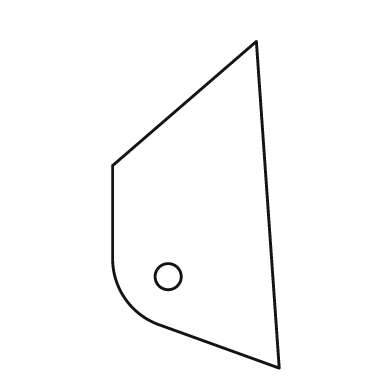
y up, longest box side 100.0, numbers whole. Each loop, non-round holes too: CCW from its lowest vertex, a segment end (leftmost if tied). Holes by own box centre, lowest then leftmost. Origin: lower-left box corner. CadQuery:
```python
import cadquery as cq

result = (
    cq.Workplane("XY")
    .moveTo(51.0, 0.0)
    .lineTo(44.0, 100.0)
    .lineTo(0.0, 62.0)
    .lineTo(0.0, 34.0)
    .threePointArc((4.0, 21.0), (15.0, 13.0))
    .close()
    .moveTo(17.0, 28.0)
    .circle(4.0)
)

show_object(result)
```